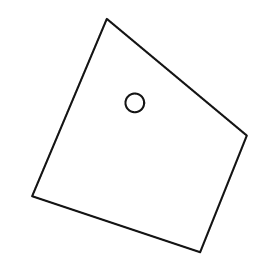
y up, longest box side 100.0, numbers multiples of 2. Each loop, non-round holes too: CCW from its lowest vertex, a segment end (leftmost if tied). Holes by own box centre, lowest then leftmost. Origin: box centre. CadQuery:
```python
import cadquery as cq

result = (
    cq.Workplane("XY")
    .moveTo(26.0, -50.0)
    .lineTo(46.0, 0.0)
    .lineTo(-14.0, 50.0)
    .lineTo(-46.0, -26.0)
    .close()
    .moveTo(-2.0, 14.0)
    .circle(4.0)
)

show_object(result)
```